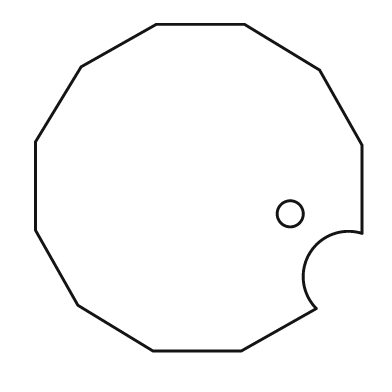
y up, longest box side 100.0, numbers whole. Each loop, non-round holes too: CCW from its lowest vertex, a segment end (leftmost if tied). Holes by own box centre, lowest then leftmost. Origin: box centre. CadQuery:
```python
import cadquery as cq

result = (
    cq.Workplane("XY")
    .moveTo(-14.0, -50.0)
    .lineTo(13.0, -50.0)
    .lineTo(36.0, -37.0)
    .threePointArc((34.0, -20.0), (50.0, -14.0))
    .lineTo(50.0, 13.0)
    .lineTo(37.0, 36.0)
    .lineTo(14.0, 50.0)
    .lineTo(-13.0, 50.0)
    .lineTo(-36.0, 37.0)
    .lineTo(-50.0, 14.0)
    .lineTo(-50.0, -13.0)
    .lineTo(-37.0, -36.0)
    .close()
    .moveTo(28.0, -8.0)
    .circle(4.0)
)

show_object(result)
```